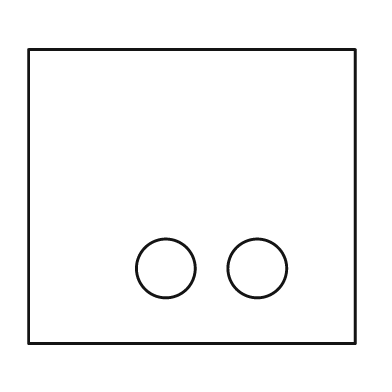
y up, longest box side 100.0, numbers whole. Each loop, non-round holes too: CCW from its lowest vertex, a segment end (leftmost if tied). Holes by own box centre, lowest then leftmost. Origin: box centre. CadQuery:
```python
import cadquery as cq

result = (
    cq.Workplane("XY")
    .moveTo(-50.0, -45.0)
    .lineTo(50.0, -45.0)
    .lineTo(50.0, 45.0)
    .lineTo(-50.0, 45.0)
    .close()
    .moveTo(-8.0, -22.0)
    .circle(9.0)
    .moveTo(20.0, -22.0)
    .circle(9.0)
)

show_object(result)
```